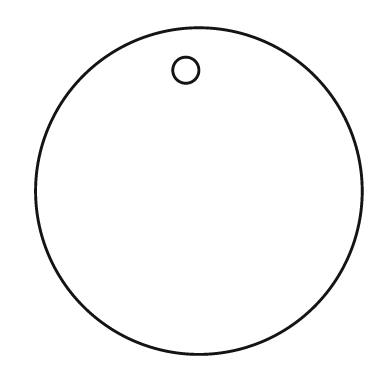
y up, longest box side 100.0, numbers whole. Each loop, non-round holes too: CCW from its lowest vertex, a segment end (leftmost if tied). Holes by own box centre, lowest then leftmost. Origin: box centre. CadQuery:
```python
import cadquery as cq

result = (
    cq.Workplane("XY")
    .moveTo(0.0, 0.0)
    .circle(50.0)
    .moveTo(-4.0, 37.0)
    .circle(4.0)
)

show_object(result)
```